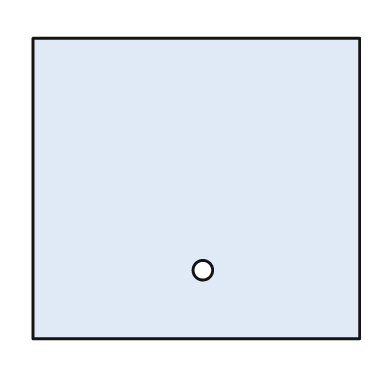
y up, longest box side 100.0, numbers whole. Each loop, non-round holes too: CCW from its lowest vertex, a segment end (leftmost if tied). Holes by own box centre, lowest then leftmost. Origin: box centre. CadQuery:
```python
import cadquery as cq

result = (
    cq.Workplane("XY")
    .moveTo(-50.0, -46.0)
    .lineTo(50.0, -46.0)
    .lineTo(50.0, 46.0)
    .lineTo(-50.0, 46.0)
    .close()
    .moveTo(2.0, -25.0)
    .circle(3.0)
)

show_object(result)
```